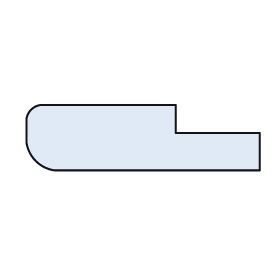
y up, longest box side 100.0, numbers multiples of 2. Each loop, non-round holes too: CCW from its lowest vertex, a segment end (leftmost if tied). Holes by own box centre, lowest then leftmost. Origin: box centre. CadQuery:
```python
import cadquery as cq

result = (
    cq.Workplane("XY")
    .moveTo(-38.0, -14.0)
    .lineTo(50.0, -14.0)
    .lineTo(50.0, 2.0)
    .lineTo(14.0, 2.0)
    .lineTo(14.0, 14.0)
    .lineTo(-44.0, 14.0)
    .threePointArc((-48.0, 12.0), (-50.0, 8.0))
    .lineTo(-50.0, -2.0)
    .threePointArc((-46.0, -10.0), (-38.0, -14.0))
    .close()
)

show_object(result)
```